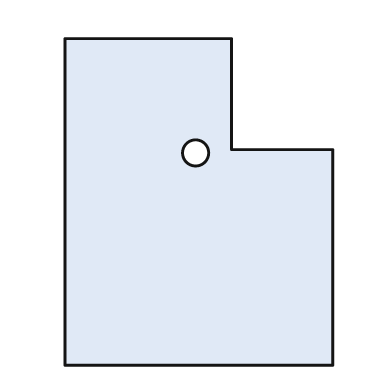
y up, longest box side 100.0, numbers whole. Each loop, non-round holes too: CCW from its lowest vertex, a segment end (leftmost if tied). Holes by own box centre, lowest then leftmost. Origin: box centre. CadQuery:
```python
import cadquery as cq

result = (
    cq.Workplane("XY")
    .moveTo(-41.0, -50.0)
    .lineTo(41.0, -50.0)
    .lineTo(41.0, 16.0)
    .lineTo(10.0, 16.0)
    .lineTo(10.0, 50.0)
    .lineTo(-41.0, 50.0)
    .close()
    .moveTo(-1.0, 15.0)
    .circle(4.0)
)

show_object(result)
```